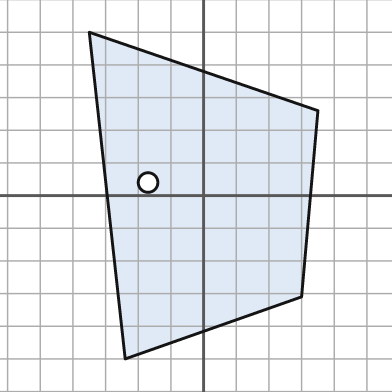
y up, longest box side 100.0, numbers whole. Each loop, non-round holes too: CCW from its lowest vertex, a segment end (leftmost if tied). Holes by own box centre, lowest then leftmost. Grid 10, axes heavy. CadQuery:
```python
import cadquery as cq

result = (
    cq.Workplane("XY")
    .moveTo(-24.0, -50.0)
    .lineTo(30.0, -31.0)
    .lineTo(35.0, 26.0)
    .lineTo(-35.0, 50.0)
    .close()
    .moveTo(-17.0, 4.0)
    .circle(3.0)
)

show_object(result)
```